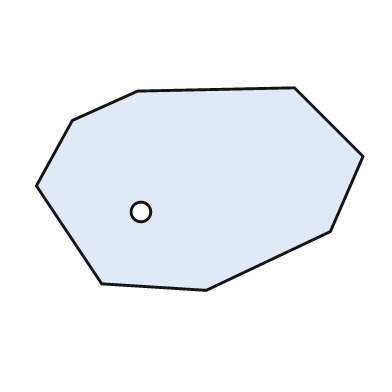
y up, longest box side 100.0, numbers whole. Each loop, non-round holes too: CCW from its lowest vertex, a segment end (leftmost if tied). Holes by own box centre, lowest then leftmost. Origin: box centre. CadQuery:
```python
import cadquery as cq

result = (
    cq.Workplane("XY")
    .moveTo(2.0, -31.0)
    .lineTo(40.0, -13.0)
    .lineTo(50.0, 10.0)
    .lineTo(29.0, 31.0)
    .lineTo(-19.0, 30.0)
    .lineTo(-39.0, 21.0)
    .lineTo(-50.0, 1.0)
    .lineTo(-30.0, -29.0)
    .close()
    .moveTo(-18.0, -7.0)
    .circle(3.0)
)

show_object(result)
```